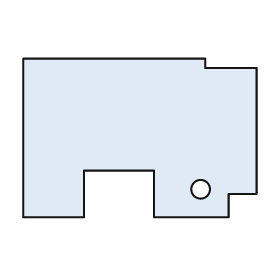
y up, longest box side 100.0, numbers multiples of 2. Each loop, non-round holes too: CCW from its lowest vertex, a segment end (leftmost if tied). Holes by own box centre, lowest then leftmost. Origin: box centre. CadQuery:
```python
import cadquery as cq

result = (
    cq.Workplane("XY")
    .moveTo(-50.0, -34.0)
    .lineTo(-24.0, -34.0)
    .lineTo(-24.0, -14.0)
    .lineTo(6.0, -14.0)
    .lineTo(6.0, -34.0)
    .lineTo(38.0, -34.0)
    .lineTo(38.0, -24.0)
    .lineTo(50.0, -24.0)
    .lineTo(50.0, 30.0)
    .lineTo(28.0, 30.0)
    .lineTo(28.0, 34.0)
    .lineTo(-50.0, 34.0)
    .close()
    .moveTo(26.0, -22.0)
    .circle(4.0)
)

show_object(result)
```